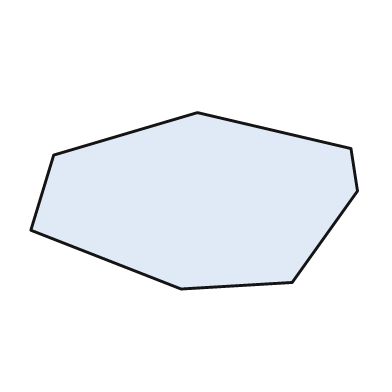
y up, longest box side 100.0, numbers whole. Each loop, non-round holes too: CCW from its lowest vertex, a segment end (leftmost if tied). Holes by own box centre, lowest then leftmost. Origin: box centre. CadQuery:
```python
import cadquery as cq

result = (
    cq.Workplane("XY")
    .moveTo(-4.0, -27.0)
    .lineTo(30.0, -25.0)
    .lineTo(50.0, 3.0)
    .lineTo(48.0, 16.0)
    .lineTo(1.0, 27.0)
    .lineTo(-43.0, 14.0)
    .lineTo(-50.0, -9.0)
    .close()
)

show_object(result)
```